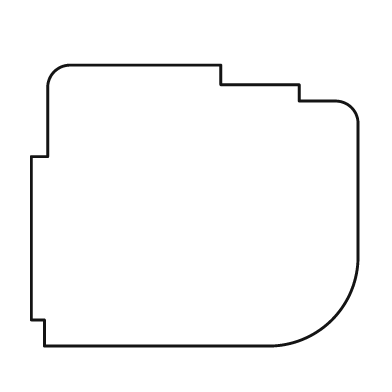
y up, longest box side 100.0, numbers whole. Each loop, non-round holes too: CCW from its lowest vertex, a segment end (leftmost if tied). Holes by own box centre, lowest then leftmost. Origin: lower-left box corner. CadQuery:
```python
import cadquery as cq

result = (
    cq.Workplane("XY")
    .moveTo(4.0, 0.0)
    .lineTo(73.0, 0.0)
    .threePointArc((92.0, 8.0), (100.0, 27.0))
    .lineTo(100.0, 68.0)
    .threePointArc((98.0, 73.0), (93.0, 75.0))
    .lineTo(82.0, 75.0)
    .lineTo(82.0, 80.0)
    .lineTo(58.0, 80.0)
    .lineTo(58.0, 86.0)
    .lineTo(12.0, 86.0)
    .threePointArc((7.0, 84.0), (5.0, 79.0))
    .lineTo(5.0, 58.0)
    .lineTo(0.0, 58.0)
    .lineTo(0.0, 8.0)
    .lineTo(4.0, 8.0)
    .close()
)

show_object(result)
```